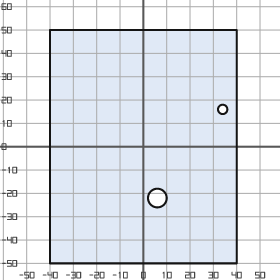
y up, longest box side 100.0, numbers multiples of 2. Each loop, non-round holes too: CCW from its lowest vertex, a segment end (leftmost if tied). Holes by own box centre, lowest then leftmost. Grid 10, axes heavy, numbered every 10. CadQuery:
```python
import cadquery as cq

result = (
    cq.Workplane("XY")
    .moveTo(-40.0, -50.0)
    .lineTo(40.0, -50.0)
    .lineTo(40.0, 50.0)
    .lineTo(-40.0, 50.0)
    .close()
    .moveTo(6.0, -22.0)
    .circle(4.0)
    .moveTo(34.0, 16.0)
    .circle(2.0)
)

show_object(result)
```